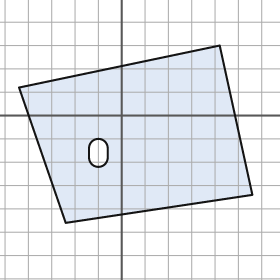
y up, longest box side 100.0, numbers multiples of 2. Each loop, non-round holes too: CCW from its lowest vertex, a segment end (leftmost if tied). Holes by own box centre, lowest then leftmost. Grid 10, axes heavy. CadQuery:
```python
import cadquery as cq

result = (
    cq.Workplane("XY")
    .moveTo(-24.0, -46.0)
    .lineTo(56.0, -34.0)
    .lineTo(42.0, 30.0)
    .lineTo(-44.0, 12.0)
    .close()
    .moveTo(-14.0, -18.0)
    .threePointArc((-10.0, -22.0), (-6.0, -18.0))
    .lineTo(-6.0, -14.0)
    .threePointArc((-10.0, -10.0), (-14.0, -14.0))
    .close()
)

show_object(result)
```